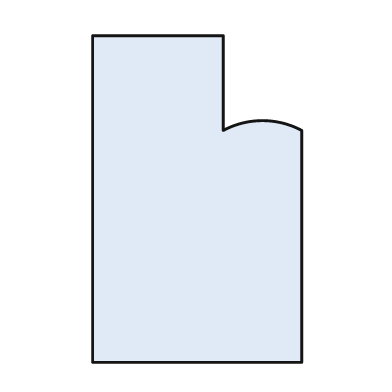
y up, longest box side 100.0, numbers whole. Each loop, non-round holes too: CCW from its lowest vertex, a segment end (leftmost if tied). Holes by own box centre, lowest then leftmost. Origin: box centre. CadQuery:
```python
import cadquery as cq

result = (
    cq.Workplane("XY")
    .moveTo(-32.0, -50.0)
    .lineTo(32.0, -50.0)
    .lineTo(32.0, 21.0)
    .threePointArc((20.0, 24.0), (8.0, 21.0))
    .lineTo(8.0, 50.0)
    .lineTo(-32.0, 50.0)
    .close()
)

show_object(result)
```